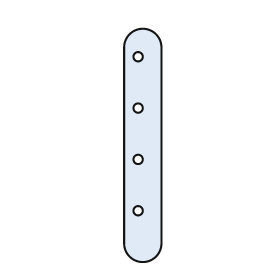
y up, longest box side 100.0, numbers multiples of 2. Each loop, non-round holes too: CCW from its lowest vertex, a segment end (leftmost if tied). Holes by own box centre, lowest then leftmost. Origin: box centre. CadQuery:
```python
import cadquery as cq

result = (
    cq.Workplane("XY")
    .moveTo(-8.0, -42.0)
    .threePointArc((0.0, -50.0), (8.0, -42.0))
    .lineTo(8.0, 42.0)
    .threePointArc((0.0, 50.0), (-8.0, 42.0))
    .close()
    .moveTo(-2.0, -28.0)
    .circle(2.0)
    .moveTo(-2.0, -6.0)
    .circle(2.0)
    .moveTo(-2.0, 16.0)
    .circle(2.0)
    .moveTo(-2.0, 38.0)
    .circle(2.0)
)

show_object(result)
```